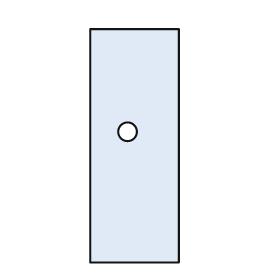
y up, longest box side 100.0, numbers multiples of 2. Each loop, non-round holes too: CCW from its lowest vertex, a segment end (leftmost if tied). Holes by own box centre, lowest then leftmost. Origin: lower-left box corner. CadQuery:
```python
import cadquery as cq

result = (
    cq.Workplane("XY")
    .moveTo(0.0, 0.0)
    .lineTo(38.0, 0.0)
    .lineTo(38.0, 100.0)
    .lineTo(0.0, 100.0)
    .close()
    .moveTo(16.0, 56.0)
    .circle(4.0)
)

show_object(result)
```